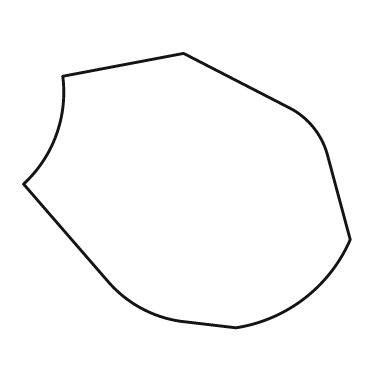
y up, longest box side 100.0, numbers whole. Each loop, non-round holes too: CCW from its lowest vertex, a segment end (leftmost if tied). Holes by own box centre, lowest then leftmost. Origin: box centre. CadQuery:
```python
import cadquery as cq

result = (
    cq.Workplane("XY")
    .moveTo(15.0, -42.0)
    .threePointArc((36.0, -33.0), (50.0, -15.0))
    .lineTo(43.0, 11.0)
    .threePointArc((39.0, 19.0), (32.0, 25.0))
    .lineTo(-1.0, 42.0)
    .lineTo(-38.0, 35.0)
    .threePointArc((-40.0, 17.0), (-50.0, 2.0))
    .lineTo(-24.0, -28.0)
    .threePointArc((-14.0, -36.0), (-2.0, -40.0))
    .close()
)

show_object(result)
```